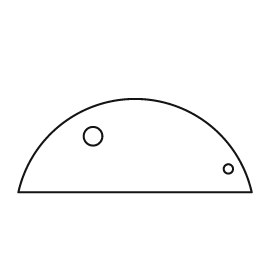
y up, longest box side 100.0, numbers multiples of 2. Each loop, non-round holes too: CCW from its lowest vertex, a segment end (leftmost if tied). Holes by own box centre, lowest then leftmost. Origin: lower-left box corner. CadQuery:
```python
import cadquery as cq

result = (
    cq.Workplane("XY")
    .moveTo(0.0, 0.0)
    .lineTo(100.0, 0.0)
    .threePointArc((50.0, 40.0), (0.0, 0.0))
    .close()
    .moveTo(90.0, 10.0)
    .circle(2.0)
    .moveTo(32.0, 24.0)
    .circle(4.0)
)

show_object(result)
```